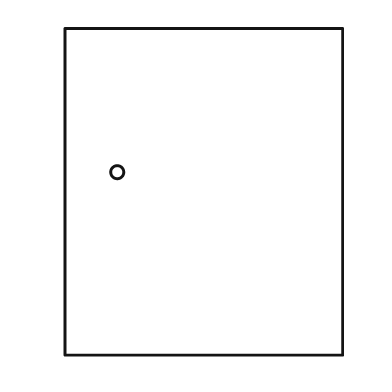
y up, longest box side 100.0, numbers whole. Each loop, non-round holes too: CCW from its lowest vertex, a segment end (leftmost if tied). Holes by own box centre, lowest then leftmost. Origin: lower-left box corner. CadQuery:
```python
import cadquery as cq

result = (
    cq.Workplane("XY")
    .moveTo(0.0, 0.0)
    .lineTo(85.0, 0.0)
    .lineTo(85.0, 100.0)
    .lineTo(0.0, 100.0)
    .close()
    .moveTo(16.0, 56.0)
    .circle(2.0)
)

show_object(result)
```